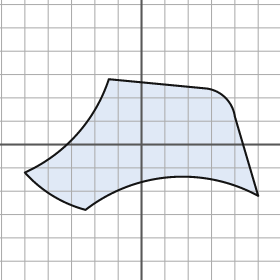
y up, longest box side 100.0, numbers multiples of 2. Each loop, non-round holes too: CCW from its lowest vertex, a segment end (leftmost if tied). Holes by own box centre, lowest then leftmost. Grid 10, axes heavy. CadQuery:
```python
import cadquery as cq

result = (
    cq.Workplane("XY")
    .moveTo(-24.0, -28.0)
    .threePointArc((12.0, -14.0), (50.0, -22.0))
    .lineTo(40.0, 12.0)
    .threePointArc((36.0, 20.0), (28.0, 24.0))
    .lineTo(-14.0, 28.0)
    .threePointArc((-28.0, 4.0), (-50.0, -12.0))
    .threePointArc((-38.0, -22.0), (-24.0, -28.0))
    .close()
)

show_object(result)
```